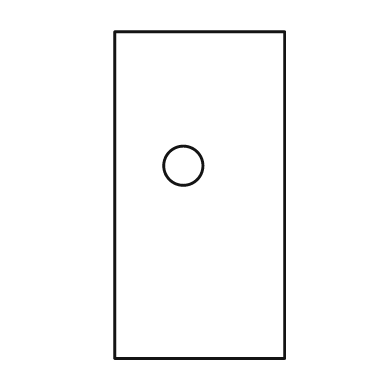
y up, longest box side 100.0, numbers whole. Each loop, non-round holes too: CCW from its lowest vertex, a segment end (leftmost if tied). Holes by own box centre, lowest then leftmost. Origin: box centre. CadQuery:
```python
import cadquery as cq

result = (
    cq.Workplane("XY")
    .moveTo(-26.0, -50.0)
    .lineTo(26.0, -50.0)
    .lineTo(26.0, 50.0)
    .lineTo(-26.0, 50.0)
    .close()
    .moveTo(-5.0, 9.0)
    .circle(6.0)
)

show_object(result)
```